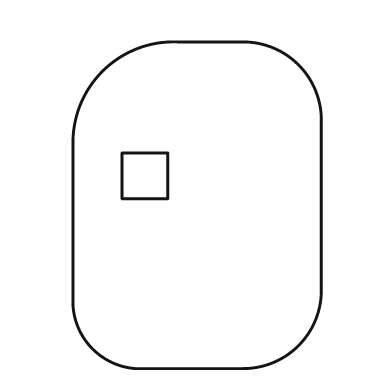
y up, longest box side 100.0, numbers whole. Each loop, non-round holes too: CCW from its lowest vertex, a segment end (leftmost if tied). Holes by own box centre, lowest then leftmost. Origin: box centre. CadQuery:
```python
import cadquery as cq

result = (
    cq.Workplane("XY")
    .moveTo(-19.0, -50.0)
    .lineTo(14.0, -50.0)
    .threePointArc((31.0, -43.0), (38.0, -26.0))
    .lineTo(38.0, 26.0)
    .threePointArc((31.0, 43.0), (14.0, 50.0))
    .lineTo(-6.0, 50.0)
    .threePointArc((-29.0, 41.0), (-38.0, 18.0))
    .lineTo(-38.0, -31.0)
    .threePointArc((-32.0, -44.0), (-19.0, -50.0))
    .close()
    .moveTo(-23.0, 2.0)
    .lineTo(-9.0, 2.0)
    .lineTo(-9.0, 16.0)
    .lineTo(-23.0, 16.0)
    .close()
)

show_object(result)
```